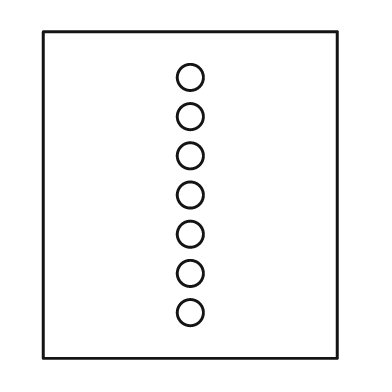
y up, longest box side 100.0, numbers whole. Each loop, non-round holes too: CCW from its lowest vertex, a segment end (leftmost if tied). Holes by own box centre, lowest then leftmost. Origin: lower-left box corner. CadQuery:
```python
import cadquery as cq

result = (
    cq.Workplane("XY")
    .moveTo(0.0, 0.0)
    .lineTo(90.0, 0.0)
    .lineTo(90.0, 100.0)
    .lineTo(0.0, 100.0)
    .close()
    .moveTo(45.0, 14.0)
    .circle(4.0)
    .moveTo(45.0, 26.0)
    .circle(4.0)
    .moveTo(45.0, 38.0)
    .circle(4.0)
    .moveTo(45.0, 50.0)
    .circle(4.0)
    .moveTo(45.0, 62.0)
    .circle(4.0)
    .moveTo(45.0, 74.0)
    .circle(4.0)
    .moveTo(45.0, 86.0)
    .circle(4.0)
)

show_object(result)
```